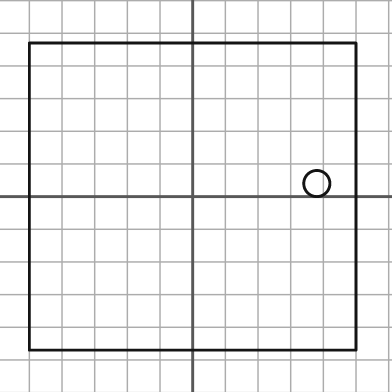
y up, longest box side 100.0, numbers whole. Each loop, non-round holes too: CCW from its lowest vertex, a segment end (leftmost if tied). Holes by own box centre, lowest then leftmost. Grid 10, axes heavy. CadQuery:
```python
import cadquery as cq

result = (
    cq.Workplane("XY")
    .moveTo(-50.0, -47.0)
    .lineTo(50.0, -47.0)
    .lineTo(50.0, 47.0)
    .lineTo(-50.0, 47.0)
    .close()
    .moveTo(38.0, 4.0)
    .circle(4.0)
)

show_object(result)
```